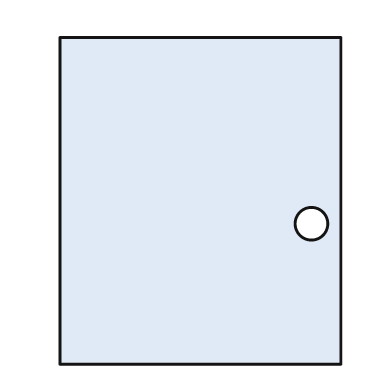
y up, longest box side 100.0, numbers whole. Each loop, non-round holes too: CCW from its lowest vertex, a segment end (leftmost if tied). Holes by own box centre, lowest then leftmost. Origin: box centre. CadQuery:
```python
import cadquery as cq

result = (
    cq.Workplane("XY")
    .moveTo(-43.0, -50.0)
    .lineTo(43.0, -50.0)
    .lineTo(43.0, 50.0)
    .lineTo(-43.0, 50.0)
    .close()
    .moveTo(34.0, -7.0)
    .circle(5.0)
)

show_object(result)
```